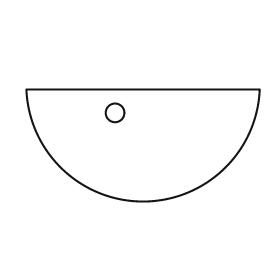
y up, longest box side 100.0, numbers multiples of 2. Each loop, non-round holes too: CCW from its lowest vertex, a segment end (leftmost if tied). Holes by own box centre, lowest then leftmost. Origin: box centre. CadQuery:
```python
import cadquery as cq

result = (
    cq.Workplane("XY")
    .moveTo(-50.0, 24.0)
    .threePointArc((0.0, -24.0), (50.0, 24.0))
    .close()
    .moveTo(-12.0, 14.0)
    .circle(4.0)
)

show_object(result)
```